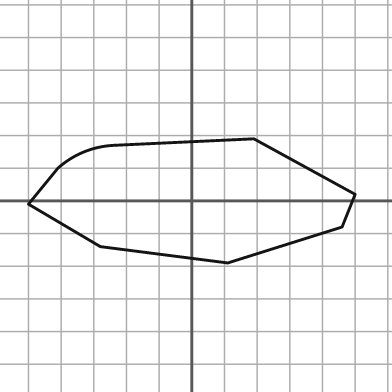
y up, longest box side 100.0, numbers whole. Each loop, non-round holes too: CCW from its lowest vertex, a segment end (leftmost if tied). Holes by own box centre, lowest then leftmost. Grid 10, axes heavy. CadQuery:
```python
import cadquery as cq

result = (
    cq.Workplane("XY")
    .moveTo(11.0, -19.0)
    .lineTo(46.0, -8.0)
    .lineTo(50.0, 2.0)
    .lineTo(19.0, 19.0)
    .lineTo(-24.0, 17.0)
    .threePointArc((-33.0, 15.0), (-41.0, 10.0))
    .lineTo(-50.0, -1.0)
    .lineTo(-28.0, -14.0)
    .close()
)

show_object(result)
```